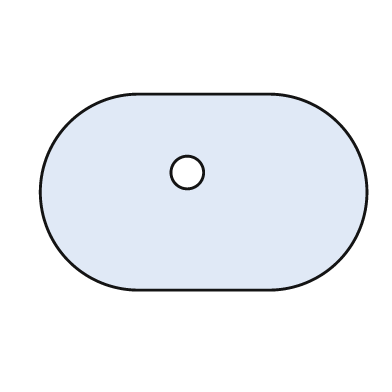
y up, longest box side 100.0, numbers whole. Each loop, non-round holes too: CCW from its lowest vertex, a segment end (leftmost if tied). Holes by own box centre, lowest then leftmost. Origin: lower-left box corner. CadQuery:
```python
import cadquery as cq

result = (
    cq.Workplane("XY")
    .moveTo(30.0, 0.0)
    .lineTo(70.0, 0.0)
    .threePointArc((100.0, 30.0), (70.0, 60.0))
    .lineTo(30.0, 60.0)
    .threePointArc((0.0, 30.0), (30.0, 0.0))
    .close()
    .moveTo(45.0, 36.0)
    .circle(5.0)
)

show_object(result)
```